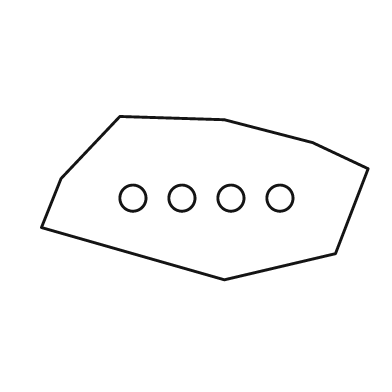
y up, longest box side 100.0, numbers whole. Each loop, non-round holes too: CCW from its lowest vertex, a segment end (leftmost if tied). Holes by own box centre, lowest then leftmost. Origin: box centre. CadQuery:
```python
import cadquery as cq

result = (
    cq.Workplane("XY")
    .moveTo(6.0, -25.0)
    .lineTo(40.0, -17.0)
    .lineTo(50.0, 9.0)
    .lineTo(33.0, 17.0)
    .lineTo(6.0, 24.0)
    .lineTo(-26.0, 25.0)
    .lineTo(-44.0, 6.0)
    .lineTo(-50.0, -9.0)
    .close()
    .moveTo(-22.0, 0.0)
    .circle(4.0)
    .moveTo(-7.0, 0.0)
    .circle(4.0)
    .moveTo(8.0, 0.0)
    .circle(4.0)
    .moveTo(23.0, 0.0)
    .circle(4.0)
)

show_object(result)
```